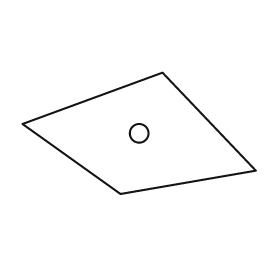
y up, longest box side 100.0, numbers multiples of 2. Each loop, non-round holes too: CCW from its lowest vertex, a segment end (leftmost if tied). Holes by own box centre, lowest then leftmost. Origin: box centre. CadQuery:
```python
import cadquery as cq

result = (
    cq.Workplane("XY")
    .moveTo(-8.0, -26.0)
    .lineTo(50.0, -16.0)
    .lineTo(10.0, 26.0)
    .lineTo(-50.0, 4.0)
    .close()
    .moveTo(0.0, 0.0)
    .circle(4.0)
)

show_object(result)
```